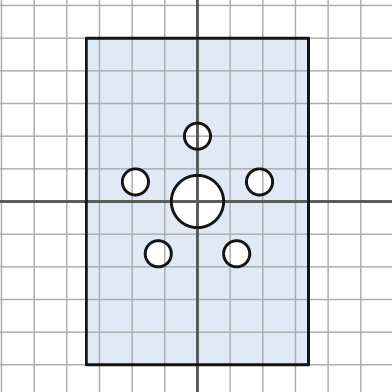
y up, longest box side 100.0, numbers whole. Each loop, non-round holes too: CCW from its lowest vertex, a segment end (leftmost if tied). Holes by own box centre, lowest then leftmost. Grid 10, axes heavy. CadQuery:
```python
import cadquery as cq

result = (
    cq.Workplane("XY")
    .moveTo(-34.0, -50.0)
    .lineTo(34.0, -50.0)
    .lineTo(34.0, 50.0)
    .lineTo(-34.0, 50.0)
    .close()
    .moveTo(-12.0, -16.0)
    .circle(4.0)
    .moveTo(12.0, -16.0)
    .circle(4.0)
    .moveTo(0.0, 0.0)
    .circle(8.0)
    .moveTo(-19.0, 6.0)
    .circle(4.0)
    .moveTo(19.0, 6.0)
    .circle(4.0)
    .moveTo(0.0, 20.0)
    .circle(4.0)
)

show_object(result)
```